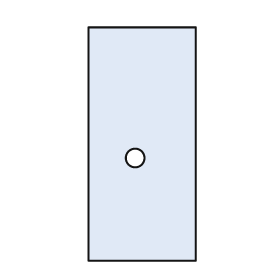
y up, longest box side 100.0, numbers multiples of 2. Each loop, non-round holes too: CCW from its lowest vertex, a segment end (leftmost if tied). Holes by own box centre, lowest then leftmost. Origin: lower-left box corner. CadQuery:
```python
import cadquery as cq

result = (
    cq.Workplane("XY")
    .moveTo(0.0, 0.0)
    .lineTo(46.0, 0.0)
    .lineTo(46.0, 100.0)
    .lineTo(0.0, 100.0)
    .close()
    .moveTo(20.0, 44.0)
    .circle(4.0)
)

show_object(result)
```